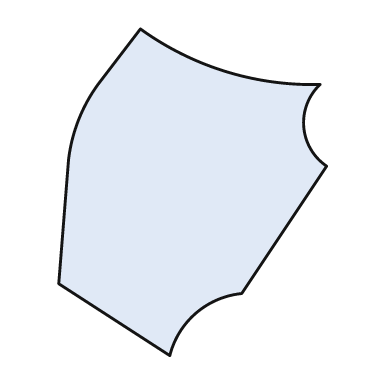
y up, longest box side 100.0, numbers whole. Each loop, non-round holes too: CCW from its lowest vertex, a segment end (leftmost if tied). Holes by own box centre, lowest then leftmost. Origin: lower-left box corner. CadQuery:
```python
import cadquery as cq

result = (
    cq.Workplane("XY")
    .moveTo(34.0, 0.0)
    .threePointArc((42.0, 13.0), (56.0, 19.0))
    .lineTo(82.0, 58.0)
    .threePointArc((75.0, 70.0), (80.0, 83.0))
    .threePointArc((51.0, 87.0), (25.0, 100.0))
    .lineTo(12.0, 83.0)
    .threePointArc((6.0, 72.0), (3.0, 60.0))
    .lineTo(0.0, 22.0)
    .close()
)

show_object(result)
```